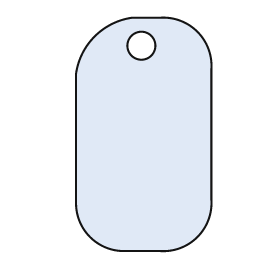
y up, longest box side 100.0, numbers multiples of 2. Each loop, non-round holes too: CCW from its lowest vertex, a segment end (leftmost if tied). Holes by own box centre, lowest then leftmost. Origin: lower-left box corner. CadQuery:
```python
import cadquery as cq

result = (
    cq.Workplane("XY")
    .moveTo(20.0, 0.0)
    .lineTo(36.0, 0.0)
    .threePointArc((52.0, 6.0), (58.0, 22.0))
    .lineTo(58.0, 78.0)
    .threePointArc((52.0, 94.0), (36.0, 100.0))
    .lineTo(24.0, 100.0)
    .threePointArc((8.0, 92.0), (0.0, 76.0))
    .lineTo(0.0, 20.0)
    .threePointArc((6.0, 6.0), (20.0, 0.0))
    .close()
    .moveTo(28.0, 88.0)
    .circle(6.0)
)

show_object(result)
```